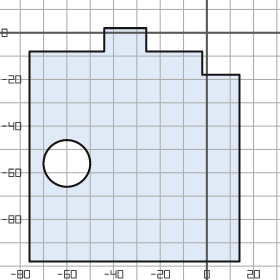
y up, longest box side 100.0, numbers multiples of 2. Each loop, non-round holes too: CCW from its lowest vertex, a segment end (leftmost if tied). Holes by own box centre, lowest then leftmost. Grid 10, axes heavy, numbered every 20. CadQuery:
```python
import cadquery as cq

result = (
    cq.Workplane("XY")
    .moveTo(-76.0, -98.0)
    .lineTo(14.0, -98.0)
    .lineTo(14.0, -18.0)
    .lineTo(-2.0, -18.0)
    .lineTo(-2.0, -8.0)
    .lineTo(-26.0, -8.0)
    .lineTo(-26.0, 2.0)
    .lineTo(-44.0, 2.0)
    .lineTo(-44.0, -8.0)
    .lineTo(-76.0, -8.0)
    .close()
    .moveTo(-60.0, -56.0)
    .circle(10.0)
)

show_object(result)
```